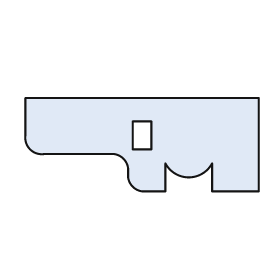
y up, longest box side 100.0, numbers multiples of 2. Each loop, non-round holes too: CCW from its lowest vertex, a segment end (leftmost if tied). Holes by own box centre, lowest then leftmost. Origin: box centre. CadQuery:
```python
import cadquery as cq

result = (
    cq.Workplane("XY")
    .moveTo(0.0, -20.0)
    .lineTo(10.0, -20.0)
    .lineTo(10.0, -8.0)
    .threePointArc((20.0, -14.0), (30.0, -8.0))
    .lineTo(30.0, -20.0)
    .lineTo(50.0, -20.0)
    .lineTo(50.0, 20.0)
    .lineTo(-50.0, 20.0)
    .lineTo(-50.0, 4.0)
    .threePointArc((-48.0, -2.0), (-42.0, -4.0))
    .lineTo(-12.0, -4.0)
    .threePointArc((-8.0, -6.0), (-6.0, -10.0))
    .lineTo(-6.0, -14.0)
    .threePointArc((-4.0, -18.0), (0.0, -20.0))
    .close()
    .moveTo(-4.0, -2.0)
    .lineTo(4.0, -2.0)
    .lineTo(4.0, 10.0)
    .lineTo(-4.0, 10.0)
    .close()
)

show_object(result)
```